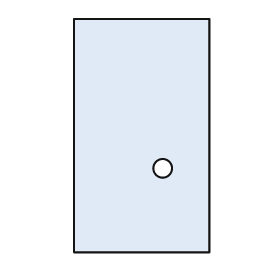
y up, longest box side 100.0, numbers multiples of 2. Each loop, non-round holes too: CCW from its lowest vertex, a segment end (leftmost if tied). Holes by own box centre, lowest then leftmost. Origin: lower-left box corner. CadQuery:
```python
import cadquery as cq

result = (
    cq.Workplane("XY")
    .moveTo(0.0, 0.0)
    .lineTo(58.0, 0.0)
    .lineTo(58.0, 100.0)
    .lineTo(0.0, 100.0)
    .close()
    .moveTo(38.0, 36.0)
    .circle(4.0)
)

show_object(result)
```